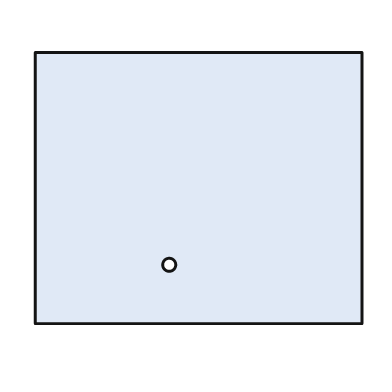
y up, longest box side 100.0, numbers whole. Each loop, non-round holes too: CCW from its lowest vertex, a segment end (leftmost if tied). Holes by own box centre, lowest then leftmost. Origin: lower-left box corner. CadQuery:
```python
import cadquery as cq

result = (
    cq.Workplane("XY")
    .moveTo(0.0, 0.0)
    .lineTo(100.0, 0.0)
    .lineTo(100.0, 83.0)
    .lineTo(0.0, 83.0)
    .close()
    .moveTo(41.0, 18.0)
    .circle(2.0)
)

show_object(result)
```